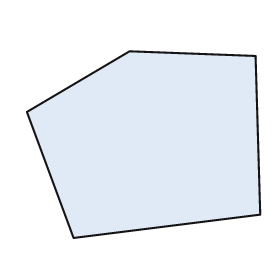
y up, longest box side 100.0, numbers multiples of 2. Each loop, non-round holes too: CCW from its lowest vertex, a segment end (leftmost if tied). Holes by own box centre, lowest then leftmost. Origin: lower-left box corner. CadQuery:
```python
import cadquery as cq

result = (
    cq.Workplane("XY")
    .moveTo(20.0, 0.0)
    .lineTo(100.0, 10.0)
    .lineTo(98.0, 78.0)
    .lineTo(44.0, 80.0)
    .lineTo(0.0, 54.0)
    .close()
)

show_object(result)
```